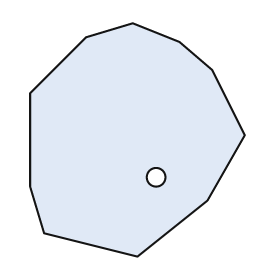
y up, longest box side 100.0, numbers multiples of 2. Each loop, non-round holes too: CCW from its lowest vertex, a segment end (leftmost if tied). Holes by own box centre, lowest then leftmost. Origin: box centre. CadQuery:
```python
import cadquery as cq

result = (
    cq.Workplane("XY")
    .moveTo(0.0, -50.0)
    .lineTo(30.0, -26.0)
    .lineTo(46.0, 2.0)
    .lineTo(32.0, 30.0)
    .lineTo(18.0, 42.0)
    .lineTo(-2.0, 50.0)
    .lineTo(-22.0, 44.0)
    .lineTo(-46.0, 20.0)
    .lineTo(-46.0, -20.0)
    .lineTo(-40.0, -40.0)
    .close()
    .moveTo(8.0, -16.0)
    .circle(4.0)
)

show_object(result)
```